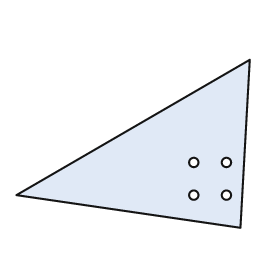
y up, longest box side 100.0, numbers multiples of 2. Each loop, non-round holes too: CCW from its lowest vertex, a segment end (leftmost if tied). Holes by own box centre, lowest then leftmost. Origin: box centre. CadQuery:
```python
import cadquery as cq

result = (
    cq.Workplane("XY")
    .moveTo(46.0, -36.0)
    .lineTo(50.0, 36.0)
    .lineTo(-50.0, -22.0)
    .close()
    .moveTo(26.0, -22.0)
    .circle(2.0)
    .moveTo(40.0, -22.0)
    .circle(2.0)
    .moveTo(26.0, -8.0)
    .circle(2.0)
    .moveTo(40.0, -8.0)
    .circle(2.0)
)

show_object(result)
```